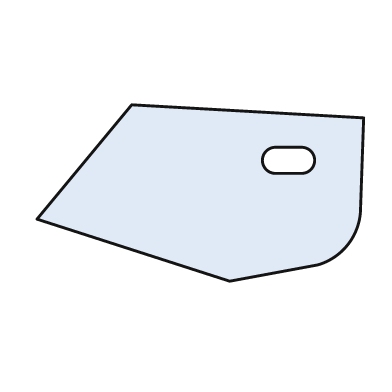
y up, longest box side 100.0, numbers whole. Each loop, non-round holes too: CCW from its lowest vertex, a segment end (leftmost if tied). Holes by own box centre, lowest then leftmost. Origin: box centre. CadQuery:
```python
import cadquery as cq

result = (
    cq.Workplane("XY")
    .moveTo(9.0, -27.0)
    .lineTo(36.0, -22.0)
    .threePointArc((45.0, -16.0), (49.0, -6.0))
    .lineTo(50.0, 23.0)
    .lineTo(-21.0, 27.0)
    .lineTo(-50.0, -8.0)
    .close()
    .moveTo(23.0, 6.0)
    .lineTo(31.0, 6.0)
    .threePointArc((35.0, 10.0), (31.0, 14.0))
    .lineTo(23.0, 14.0)
    .threePointArc((19.0, 10.0), (23.0, 6.0))
    .close()
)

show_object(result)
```